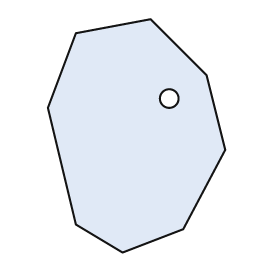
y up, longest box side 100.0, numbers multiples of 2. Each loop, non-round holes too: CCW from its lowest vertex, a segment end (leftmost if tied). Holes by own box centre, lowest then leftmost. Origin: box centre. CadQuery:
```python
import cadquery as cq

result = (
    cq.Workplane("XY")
    .moveTo(-6.0, -50.0)
    .lineTo(20.0, -40.0)
    .lineTo(38.0, -6.0)
    .lineTo(30.0, 26.0)
    .lineTo(6.0, 50.0)
    .lineTo(-26.0, 44.0)
    .lineTo(-38.0, 12.0)
    .lineTo(-26.0, -38.0)
    .close()
    .moveTo(14.0, 16.0)
    .circle(4.0)
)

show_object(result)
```